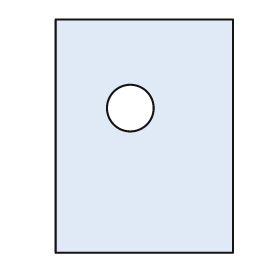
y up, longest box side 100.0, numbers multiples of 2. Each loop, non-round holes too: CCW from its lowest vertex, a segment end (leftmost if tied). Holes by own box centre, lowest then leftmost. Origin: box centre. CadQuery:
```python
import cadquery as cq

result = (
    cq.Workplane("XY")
    .moveTo(-38.0, -50.0)
    .lineTo(38.0, -50.0)
    .lineTo(38.0, 50.0)
    .lineTo(-38.0, 50.0)
    .close()
    .moveTo(-6.0, 12.0)
    .circle(10.0)
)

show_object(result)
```